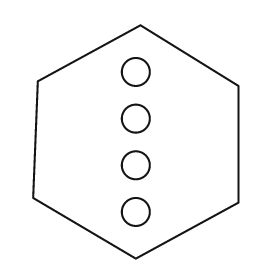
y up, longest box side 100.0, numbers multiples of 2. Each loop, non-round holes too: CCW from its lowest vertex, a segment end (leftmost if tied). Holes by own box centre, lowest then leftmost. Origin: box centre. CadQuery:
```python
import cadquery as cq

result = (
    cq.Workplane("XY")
    .moveTo(0.0, -50.0)
    .lineTo(44.0, -26.0)
    .lineTo(44.0, 24.0)
    .lineTo(2.0, 50.0)
    .lineTo(-42.0, 26.0)
    .lineTo(-44.0, -24.0)
    .close()
    .moveTo(0.0, -30.0)
    .circle(6.0)
    .moveTo(0.0, -10.0)
    .circle(6.0)
    .moveTo(0.0, 10.0)
    .circle(6.0)
    .moveTo(0.0, 30.0)
    .circle(6.0)
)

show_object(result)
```